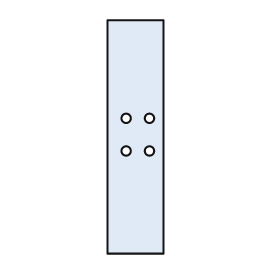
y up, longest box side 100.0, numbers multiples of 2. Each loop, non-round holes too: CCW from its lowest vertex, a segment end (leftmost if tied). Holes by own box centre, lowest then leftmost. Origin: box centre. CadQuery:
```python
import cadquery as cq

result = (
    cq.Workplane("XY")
    .moveTo(-12.0, -50.0)
    .lineTo(12.0, -50.0)
    .lineTo(12.0, 50.0)
    .lineTo(-12.0, 50.0)
    .close()
    .moveTo(-4.0, -6.0)
    .circle(2.0)
    .moveTo(6.0, -6.0)
    .circle(2.0)
    .moveTo(-4.0, 8.0)
    .circle(2.0)
    .moveTo(6.0, 8.0)
    .circle(2.0)
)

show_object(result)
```